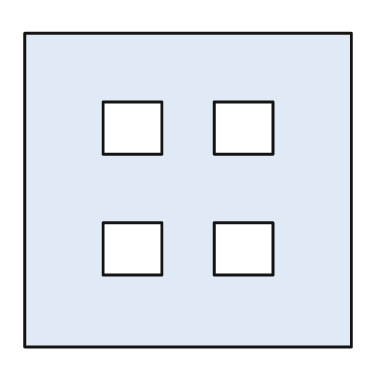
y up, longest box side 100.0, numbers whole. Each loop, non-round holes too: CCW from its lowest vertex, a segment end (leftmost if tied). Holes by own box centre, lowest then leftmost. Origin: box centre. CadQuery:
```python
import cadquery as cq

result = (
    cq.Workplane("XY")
    .moveTo(-50.0, -48.0)
    .lineTo(50.0, -48.0)
    .lineTo(50.0, 48.0)
    .lineTo(-50.0, 48.0)
    .close()
    .moveTo(-26.0, -26.0)
    .lineTo(-8.0, -26.0)
    .lineTo(-8.0, -10.0)
    .lineTo(-26.0, -10.0)
    .close()
    .moveTo(8.0, -26.0)
    .lineTo(26.0, -26.0)
    .lineTo(26.0, -10.0)
    .lineTo(8.0, -10.0)
    .close()
    .moveTo(-26.0, 11.0)
    .lineTo(-8.0, 11.0)
    .lineTo(-8.0, 27.0)
    .lineTo(-26.0, 27.0)
    .close()
    .moveTo(8.0, 11.0)
    .lineTo(26.0, 11.0)
    .lineTo(26.0, 27.0)
    .lineTo(8.0, 27.0)
    .close()
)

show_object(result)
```